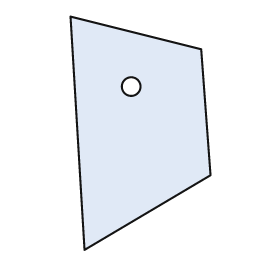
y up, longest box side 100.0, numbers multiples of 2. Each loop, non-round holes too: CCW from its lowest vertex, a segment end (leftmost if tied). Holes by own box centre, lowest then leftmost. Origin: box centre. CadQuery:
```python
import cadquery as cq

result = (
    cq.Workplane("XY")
    .moveTo(-24.0, -50.0)
    .lineTo(30.0, -18.0)
    .lineTo(26.0, 36.0)
    .lineTo(-30.0, 50.0)
    .close()
    .moveTo(-4.0, 20.0)
    .circle(4.0)
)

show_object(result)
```